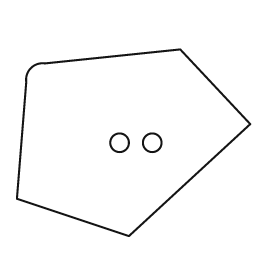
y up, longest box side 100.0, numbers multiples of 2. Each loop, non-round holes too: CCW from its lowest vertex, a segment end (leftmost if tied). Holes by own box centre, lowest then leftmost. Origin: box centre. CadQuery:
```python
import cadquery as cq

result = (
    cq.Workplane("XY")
    .moveTo(-2.0, -40.0)
    .lineTo(50.0, 8.0)
    .lineTo(20.0, 40.0)
    .lineTo(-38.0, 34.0)
    .threePointArc((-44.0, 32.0), (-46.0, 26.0))
    .lineTo(-50.0, -24.0)
    .close()
    .moveTo(-6.0, 0.0)
    .circle(4.0)
    .moveTo(8.0, 0.0)
    .circle(4.0)
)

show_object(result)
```